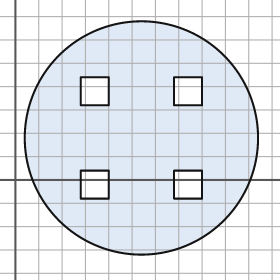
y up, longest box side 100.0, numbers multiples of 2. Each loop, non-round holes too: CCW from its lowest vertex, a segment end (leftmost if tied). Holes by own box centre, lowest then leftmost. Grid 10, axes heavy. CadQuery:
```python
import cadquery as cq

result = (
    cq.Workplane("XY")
    .moveTo(54.0, 18.0)
    .circle(50.0)
    .moveTo(28.0, -8.0)
    .lineTo(40.0, -8.0)
    .lineTo(40.0, 4.0)
    .lineTo(28.0, 4.0)
    .close()
    .moveTo(68.0, -8.0)
    .lineTo(80.0, -8.0)
    .lineTo(80.0, 4.0)
    .lineTo(68.0, 4.0)
    .close()
    .moveTo(28.0, 32.0)
    .lineTo(40.0, 32.0)
    .lineTo(40.0, 44.0)
    .lineTo(28.0, 44.0)
    .close()
    .moveTo(68.0, 32.0)
    .lineTo(80.0, 32.0)
    .lineTo(80.0, 44.0)
    .lineTo(68.0, 44.0)
    .close()
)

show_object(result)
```